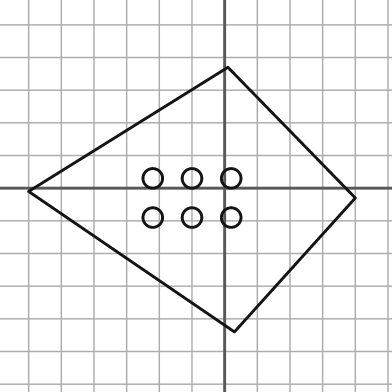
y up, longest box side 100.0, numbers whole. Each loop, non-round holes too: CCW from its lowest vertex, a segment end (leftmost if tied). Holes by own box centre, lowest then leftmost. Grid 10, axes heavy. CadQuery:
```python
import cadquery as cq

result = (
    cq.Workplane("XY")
    .moveTo(3.0, -44.0)
    .lineTo(40.0, -3.0)
    .lineTo(1.0, 37.0)
    .lineTo(-60.0, -1.0)
    .close()
    .moveTo(-22.0, -9.0)
    .circle(3.0)
    .moveTo(-10.0, -9.0)
    .circle(3.0)
    .moveTo(2.0, -9.0)
    .circle(3.0)
    .moveTo(-22.0, 3.0)
    .circle(3.0)
    .moveTo(-10.0, 3.0)
    .circle(3.0)
    .moveTo(2.0, 3.0)
    .circle(3.0)
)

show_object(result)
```